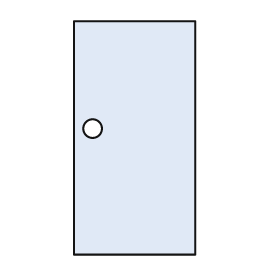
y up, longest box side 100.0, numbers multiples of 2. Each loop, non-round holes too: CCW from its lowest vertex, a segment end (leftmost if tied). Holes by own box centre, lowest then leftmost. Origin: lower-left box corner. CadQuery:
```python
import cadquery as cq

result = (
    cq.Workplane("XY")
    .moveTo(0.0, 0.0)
    .lineTo(52.0, 0.0)
    .lineTo(52.0, 100.0)
    .lineTo(0.0, 100.0)
    .close()
    .moveTo(8.0, 54.0)
    .circle(4.0)
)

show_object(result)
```